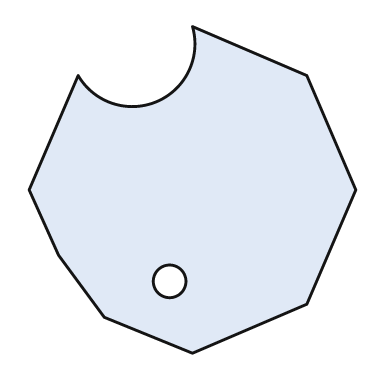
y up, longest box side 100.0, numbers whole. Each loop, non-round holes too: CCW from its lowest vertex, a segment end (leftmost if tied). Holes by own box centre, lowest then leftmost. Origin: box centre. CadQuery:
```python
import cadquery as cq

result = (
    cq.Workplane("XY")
    .moveTo(0.0, -50.0)
    .lineTo(35.0, -35.0)
    .lineTo(50.0, 0.0)
    .lineTo(35.0, 35.0)
    .lineTo(0.0, 50.0)
    .threePointArc((-11.0, 27.0), (-35.0, 35.0))
    .lineTo(-50.0, 0.0)
    .lineTo(-41.0, -20.0)
    .lineTo(-27.0, -39.0)
    .close()
    .moveTo(-7.0, -28.0)
    .circle(5.0)
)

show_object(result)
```